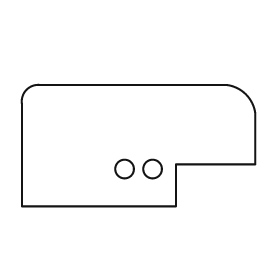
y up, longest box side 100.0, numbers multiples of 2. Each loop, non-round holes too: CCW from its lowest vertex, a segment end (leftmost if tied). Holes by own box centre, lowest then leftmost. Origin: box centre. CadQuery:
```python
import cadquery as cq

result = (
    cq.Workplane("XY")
    .moveTo(-50.0, -26.0)
    .lineTo(16.0, -26.0)
    .lineTo(16.0, -8.0)
    .lineTo(50.0, -8.0)
    .lineTo(50.0, 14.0)
    .threePointArc((46.0, 22.0), (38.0, 26.0))
    .lineTo(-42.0, 26.0)
    .threePointArc((-48.0, 24.0), (-50.0, 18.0))
    .close()
    .moveTo(-6.0, -10.0)
    .circle(4.0)
    .moveTo(6.0, -10.0)
    .circle(4.0)
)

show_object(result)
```